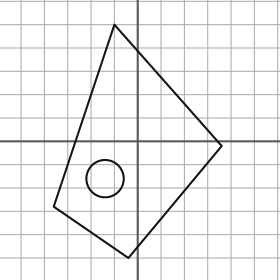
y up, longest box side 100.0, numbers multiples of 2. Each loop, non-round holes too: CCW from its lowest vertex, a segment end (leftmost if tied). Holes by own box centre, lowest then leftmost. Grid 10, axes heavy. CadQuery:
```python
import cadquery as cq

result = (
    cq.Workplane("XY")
    .moveTo(-4.0, -50.0)
    .lineTo(36.0, -2.0)
    .lineTo(-10.0, 50.0)
    .lineTo(-36.0, -28.0)
    .close()
    .moveTo(-14.0, -16.0)
    .circle(8.0)
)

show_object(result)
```